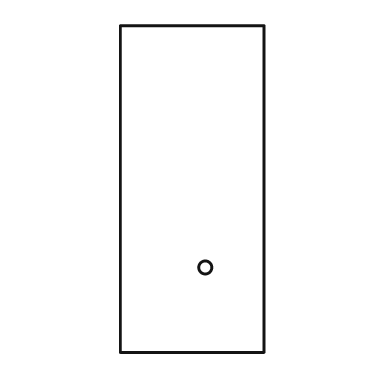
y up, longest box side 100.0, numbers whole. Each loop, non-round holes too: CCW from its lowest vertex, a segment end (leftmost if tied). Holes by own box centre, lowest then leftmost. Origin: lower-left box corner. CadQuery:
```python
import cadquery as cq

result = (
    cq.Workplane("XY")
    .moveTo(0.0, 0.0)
    .lineTo(44.0, 0.0)
    .lineTo(44.0, 100.0)
    .lineTo(0.0, 100.0)
    .close()
    .moveTo(26.0, 26.0)
    .circle(2.0)
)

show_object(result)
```